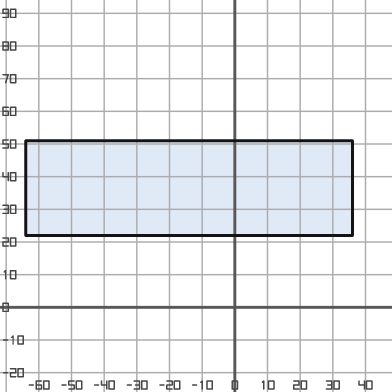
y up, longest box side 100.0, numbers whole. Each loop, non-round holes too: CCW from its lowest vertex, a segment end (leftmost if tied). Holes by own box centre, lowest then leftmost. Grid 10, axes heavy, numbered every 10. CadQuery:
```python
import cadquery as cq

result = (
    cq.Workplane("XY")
    .moveTo(-64.0, 22.0)
    .lineTo(36.0, 22.0)
    .lineTo(36.0, 51.0)
    .lineTo(-64.0, 51.0)
    .close()
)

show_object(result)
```